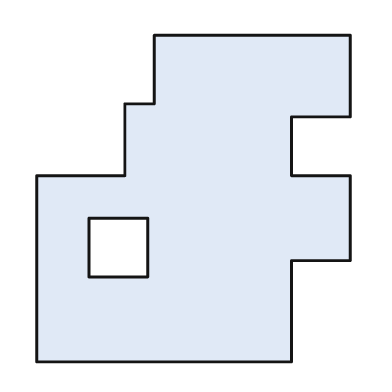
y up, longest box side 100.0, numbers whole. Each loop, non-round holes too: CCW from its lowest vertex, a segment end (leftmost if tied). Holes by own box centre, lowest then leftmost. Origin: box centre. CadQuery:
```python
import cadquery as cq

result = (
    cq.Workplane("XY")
    .moveTo(-48.0, -50.0)
    .lineTo(30.0, -50.0)
    .lineTo(30.0, -19.0)
    .lineTo(48.0, -19.0)
    .lineTo(48.0, 7.0)
    .lineTo(30.0, 7.0)
    .lineTo(30.0, 25.0)
    .lineTo(48.0, 25.0)
    .lineTo(48.0, 50.0)
    .lineTo(-12.0, 50.0)
    .lineTo(-12.0, 29.0)
    .lineTo(-21.0, 29.0)
    .lineTo(-21.0, 7.0)
    .lineTo(-48.0, 7.0)
    .close()
    .moveTo(-32.0, -24.0)
    .lineTo(-14.0, -24.0)
    .lineTo(-14.0, -6.0)
    .lineTo(-32.0, -6.0)
    .close()
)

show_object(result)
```